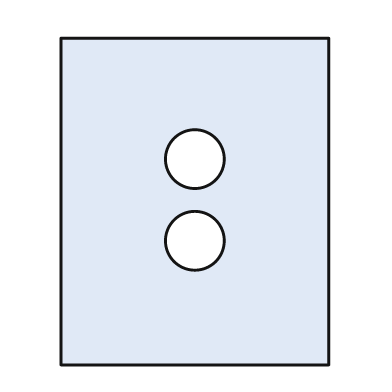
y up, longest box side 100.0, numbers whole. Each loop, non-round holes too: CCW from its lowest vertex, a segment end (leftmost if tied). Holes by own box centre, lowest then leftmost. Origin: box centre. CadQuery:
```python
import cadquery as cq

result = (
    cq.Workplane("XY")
    .moveTo(-41.0, -50.0)
    .lineTo(41.0, -50.0)
    .lineTo(41.0, 50.0)
    .lineTo(-41.0, 50.0)
    .close()
    .moveTo(0.0, -12.0)
    .circle(9.0)
    .moveTo(0.0, 13.0)
    .circle(9.0)
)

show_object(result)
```